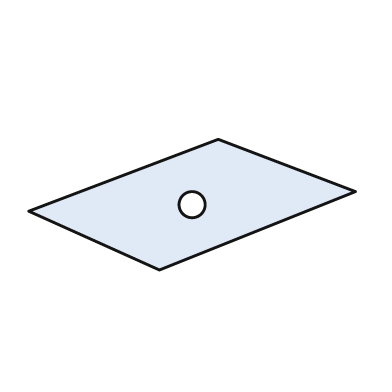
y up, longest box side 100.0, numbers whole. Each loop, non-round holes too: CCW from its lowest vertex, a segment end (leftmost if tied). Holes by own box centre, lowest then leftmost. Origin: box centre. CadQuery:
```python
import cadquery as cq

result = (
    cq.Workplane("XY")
    .moveTo(-10.0, -20.0)
    .lineTo(50.0, 4.0)
    .lineTo(8.0, 20.0)
    .lineTo(-50.0, -2.0)
    .close()
    .moveTo(0.0, 0.0)
    .circle(4.0)
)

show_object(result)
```